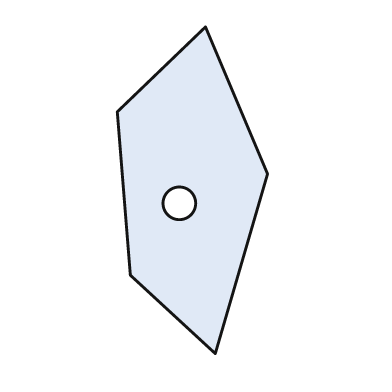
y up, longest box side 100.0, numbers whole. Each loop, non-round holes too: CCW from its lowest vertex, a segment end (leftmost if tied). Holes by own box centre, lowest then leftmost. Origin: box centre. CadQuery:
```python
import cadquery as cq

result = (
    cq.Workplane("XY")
    .moveTo(7.0, -50.0)
    .lineTo(23.0, 5.0)
    .lineTo(4.0, 50.0)
    .lineTo(-23.0, 24.0)
    .lineTo(-19.0, -26.0)
    .close()
    .moveTo(-4.0, -4.0)
    .circle(5.0)
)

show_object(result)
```